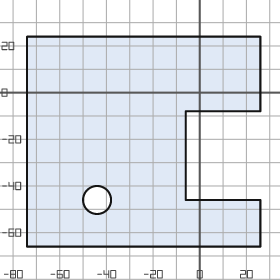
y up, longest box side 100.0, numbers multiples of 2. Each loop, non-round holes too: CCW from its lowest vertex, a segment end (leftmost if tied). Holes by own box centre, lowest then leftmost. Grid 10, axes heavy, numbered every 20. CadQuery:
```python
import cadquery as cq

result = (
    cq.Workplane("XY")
    .moveTo(-74.0, -66.0)
    .lineTo(26.0, -66.0)
    .lineTo(26.0, -46.0)
    .lineTo(-6.0, -46.0)
    .lineTo(-6.0, -8.0)
    .lineTo(26.0, -8.0)
    .lineTo(26.0, 24.0)
    .lineTo(-74.0, 24.0)
    .close()
    .moveTo(-44.0, -46.0)
    .circle(6.0)
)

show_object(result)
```